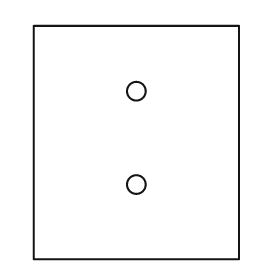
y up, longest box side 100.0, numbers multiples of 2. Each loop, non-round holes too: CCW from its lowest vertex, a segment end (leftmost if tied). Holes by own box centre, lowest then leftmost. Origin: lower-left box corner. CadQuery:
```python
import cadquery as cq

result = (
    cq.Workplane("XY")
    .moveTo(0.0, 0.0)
    .lineTo(88.0, 0.0)
    .lineTo(88.0, 100.0)
    .lineTo(0.0, 100.0)
    .close()
    .moveTo(44.0, 32.0)
    .circle(4.0)
    .moveTo(44.0, 72.0)
    .circle(4.0)
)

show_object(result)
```